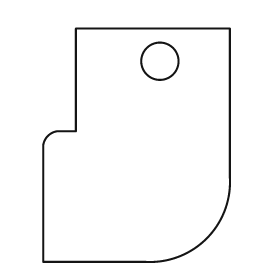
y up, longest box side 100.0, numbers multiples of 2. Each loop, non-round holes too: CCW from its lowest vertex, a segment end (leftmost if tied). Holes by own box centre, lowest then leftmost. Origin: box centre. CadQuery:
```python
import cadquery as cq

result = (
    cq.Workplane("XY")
    .moveTo(-40.0, -50.0)
    .lineTo(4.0, -50.0)
    .threePointArc((30.0, -40.0), (40.0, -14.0))
    .lineTo(40.0, 50.0)
    .lineTo(-26.0, 50.0)
    .lineTo(-26.0, 6.0)
    .lineTo(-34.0, 6.0)
    .threePointArc((-38.0, 4.0), (-40.0, 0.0))
    .close()
    .moveTo(10.0, 36.0)
    .circle(8.0)
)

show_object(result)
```